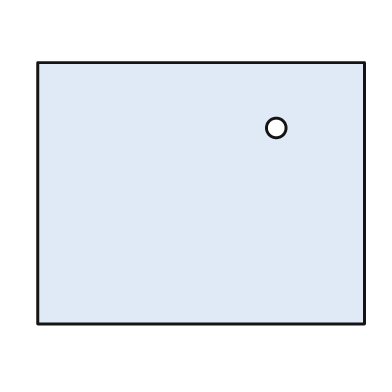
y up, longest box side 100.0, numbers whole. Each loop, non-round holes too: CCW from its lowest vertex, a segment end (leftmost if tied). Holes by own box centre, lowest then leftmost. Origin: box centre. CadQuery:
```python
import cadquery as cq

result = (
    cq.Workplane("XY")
    .moveTo(-50.0, -40.0)
    .lineTo(50.0, -40.0)
    .lineTo(50.0, 40.0)
    .lineTo(-50.0, 40.0)
    .close()
    .moveTo(23.0, 20.0)
    .circle(3.0)
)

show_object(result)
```